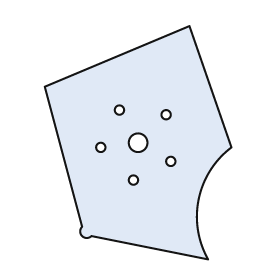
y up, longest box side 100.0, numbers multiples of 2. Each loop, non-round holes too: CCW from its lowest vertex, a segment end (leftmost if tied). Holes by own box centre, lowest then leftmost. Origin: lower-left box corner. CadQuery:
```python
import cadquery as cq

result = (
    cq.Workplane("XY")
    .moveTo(70.0, 0.0)
    .threePointArc((66.0, 26.0), (80.0, 48.0))
    .lineTo(62.0, 100.0)
    .lineTo(0.0, 74.0)
    .lineTo(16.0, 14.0)
    .threePointArc((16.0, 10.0), (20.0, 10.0))
    .close()
    .moveTo(38.0, 34.0)
    .circle(2.0)
    .moveTo(54.0, 42.0)
    .circle(2.0)
    .moveTo(24.0, 48.0)
    .circle(2.0)
    .moveTo(40.0, 50.0)
    .circle(4.0)
    .moveTo(52.0, 62.0)
    .circle(2.0)
    .moveTo(32.0, 64.0)
    .circle(2.0)
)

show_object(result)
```